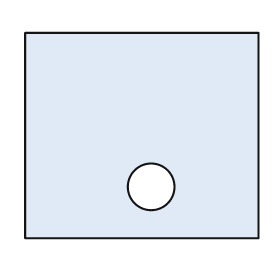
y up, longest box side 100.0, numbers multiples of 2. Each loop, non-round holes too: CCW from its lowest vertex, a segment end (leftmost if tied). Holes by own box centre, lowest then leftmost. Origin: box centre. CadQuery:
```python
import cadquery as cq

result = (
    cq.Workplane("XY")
    .moveTo(-50.0, -44.0)
    .lineTo(50.0, -44.0)
    .lineTo(50.0, 44.0)
    .lineTo(-50.0, 44.0)
    .close()
    .moveTo(4.0, -22.0)
    .circle(10.0)
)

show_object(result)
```